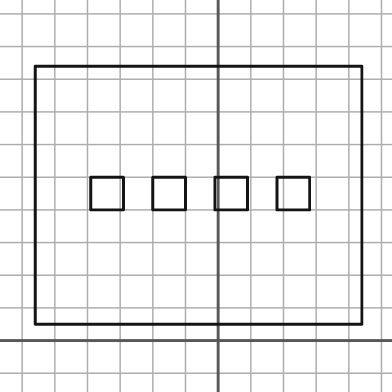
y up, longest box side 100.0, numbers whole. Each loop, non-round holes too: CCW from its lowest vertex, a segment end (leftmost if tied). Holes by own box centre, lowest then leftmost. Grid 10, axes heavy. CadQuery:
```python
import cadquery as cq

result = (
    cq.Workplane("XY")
    .moveTo(-56.0, 5.0)
    .lineTo(44.0, 5.0)
    .lineTo(44.0, 84.0)
    .lineTo(-56.0, 84.0)
    .close()
    .moveTo(-39.0, 40.0)
    .lineTo(-29.0, 40.0)
    .lineTo(-29.0, 50.0)
    .lineTo(-39.0, 50.0)
    .close()
    .moveTo(-20.0, 40.0)
    .lineTo(-10.0, 40.0)
    .lineTo(-10.0, 50.0)
    .lineTo(-20.0, 50.0)
    .close()
    .moveTo(-1.0, 40.0)
    .lineTo(9.0, 40.0)
    .lineTo(9.0, 50.0)
    .lineTo(-1.0, 50.0)
    .close()
    .moveTo(18.0, 40.0)
    .lineTo(28.0, 40.0)
    .lineTo(28.0, 50.0)
    .lineTo(18.0, 50.0)
    .close()
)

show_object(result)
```